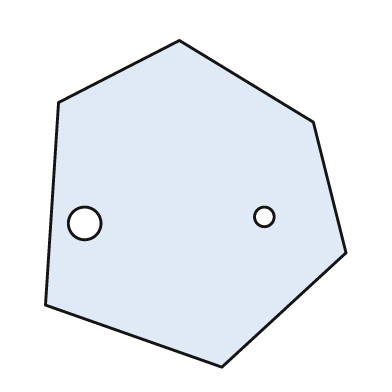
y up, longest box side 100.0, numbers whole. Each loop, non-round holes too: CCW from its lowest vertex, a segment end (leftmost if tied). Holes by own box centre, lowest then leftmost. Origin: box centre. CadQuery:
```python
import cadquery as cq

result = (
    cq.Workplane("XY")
    .moveTo(8.0, -50.0)
    .lineTo(46.0, -15.0)
    .lineTo(36.0, 25.0)
    .lineTo(-5.0, 50.0)
    .lineTo(-42.0, 31.0)
    .lineTo(-46.0, -31.0)
    .close()
    .moveTo(-34.0, -6.0)
    .circle(5.0)
    .moveTo(21.0, -4.0)
    .circle(3.0)
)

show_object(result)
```